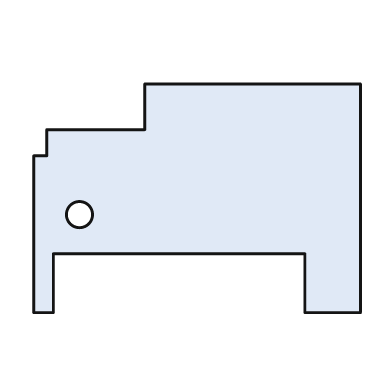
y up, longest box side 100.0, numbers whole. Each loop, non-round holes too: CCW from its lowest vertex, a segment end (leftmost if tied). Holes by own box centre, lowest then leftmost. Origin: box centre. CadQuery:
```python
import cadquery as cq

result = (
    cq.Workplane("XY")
    .moveTo(-50.0, -35.0)
    .lineTo(-44.0, -35.0)
    .lineTo(-44.0, -17.0)
    .lineTo(33.0, -17.0)
    .lineTo(33.0, -35.0)
    .lineTo(50.0, -35.0)
    .lineTo(50.0, 35.0)
    .lineTo(-16.0, 35.0)
    .lineTo(-16.0, 21.0)
    .lineTo(-46.0, 21.0)
    .lineTo(-46.0, 13.0)
    .lineTo(-50.0, 13.0)
    .close()
    .moveTo(-36.0, -5.0)
    .circle(4.0)
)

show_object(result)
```